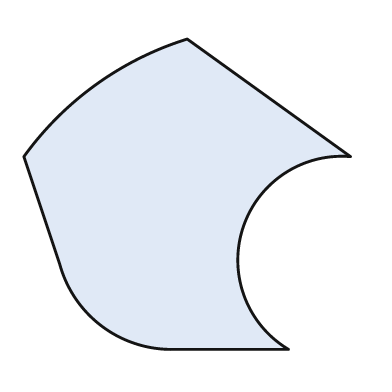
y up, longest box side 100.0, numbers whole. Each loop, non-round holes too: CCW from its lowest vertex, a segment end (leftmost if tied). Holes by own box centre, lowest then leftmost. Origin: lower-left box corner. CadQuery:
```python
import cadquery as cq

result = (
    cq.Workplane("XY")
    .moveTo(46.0, 0.0)
    .lineTo(81.0, 0.0)
    .threePointArc((67.0, 37.0), (100.0, 59.0))
    .lineTo(50.0, 95.0)
    .threePointArc((22.0, 81.0), (0.0, 59.0))
    .lineTo(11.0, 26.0)
    .threePointArc((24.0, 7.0), (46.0, 0.0))
    .close()
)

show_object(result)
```